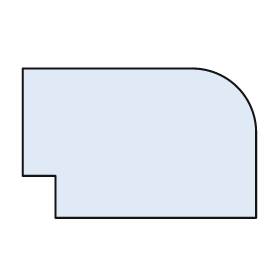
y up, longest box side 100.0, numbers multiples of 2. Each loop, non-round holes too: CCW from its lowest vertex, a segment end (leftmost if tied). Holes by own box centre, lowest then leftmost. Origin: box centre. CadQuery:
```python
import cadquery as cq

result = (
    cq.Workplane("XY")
    .moveTo(-36.0, -32.0)
    .lineTo(50.0, -32.0)
    .lineTo(50.0, 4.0)
    .threePointArc((42.0, 24.0), (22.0, 32.0))
    .lineTo(-50.0, 32.0)
    .lineTo(-50.0, -14.0)
    .lineTo(-36.0, -14.0)
    .close()
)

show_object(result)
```